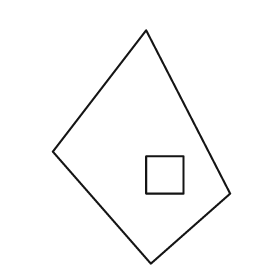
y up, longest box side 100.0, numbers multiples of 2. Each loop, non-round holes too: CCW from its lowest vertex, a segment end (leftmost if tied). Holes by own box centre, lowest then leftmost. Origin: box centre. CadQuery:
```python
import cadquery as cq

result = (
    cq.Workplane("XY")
    .moveTo(4.0, -50.0)
    .lineTo(38.0, -20.0)
    .lineTo(2.0, 50.0)
    .lineTo(-38.0, -2.0)
    .close()
    .moveTo(2.0, -20.0)
    .lineTo(18.0, -20.0)
    .lineTo(18.0, -4.0)
    .lineTo(2.0, -4.0)
    .close()
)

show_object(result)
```